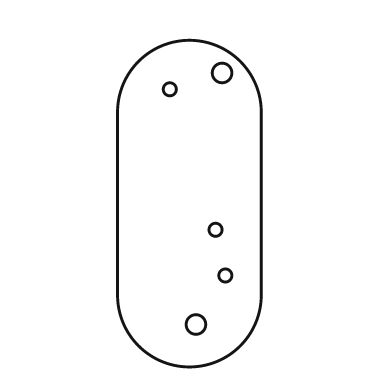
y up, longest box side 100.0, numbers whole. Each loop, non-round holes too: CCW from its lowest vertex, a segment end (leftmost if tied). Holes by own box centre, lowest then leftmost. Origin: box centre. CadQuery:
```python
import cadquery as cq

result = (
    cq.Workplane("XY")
    .moveTo(-22.0, -28.0)
    .threePointArc((0.0, -50.0), (22.0, -28.0))
    .lineTo(22.0, 28.0)
    .threePointArc((0.0, 50.0), (-22.0, 28.0))
    .close()
    .moveTo(2.0, -37.0)
    .circle(3.0)
    .moveTo(11.0, -22.0)
    .circle(2.0)
    .moveTo(8.0, -8.0)
    .circle(2.0)
    .moveTo(-6.0, 35.0)
    .circle(2.0)
    .moveTo(10.0, 40.0)
    .circle(3.0)
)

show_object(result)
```